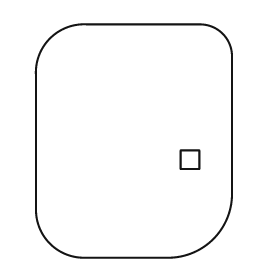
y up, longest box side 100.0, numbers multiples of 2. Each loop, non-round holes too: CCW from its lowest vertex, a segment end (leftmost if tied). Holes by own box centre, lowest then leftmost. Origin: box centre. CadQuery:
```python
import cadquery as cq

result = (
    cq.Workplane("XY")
    .moveTo(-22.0, -50.0)
    .lineTo(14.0, -50.0)
    .threePointArc((34.0, -42.0), (42.0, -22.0))
    .lineTo(42.0, 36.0)
    .threePointArc((38.0, 46.0), (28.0, 50.0))
    .lineTo(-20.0, 50.0)
    .threePointArc((-36.0, 44.0), (-42.0, 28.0))
    .lineTo(-42.0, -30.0)
    .threePointArc((-36.0, -44.0), (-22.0, -50.0))
    .close()
    .moveTo(20.0, -12.0)
    .lineTo(28.0, -12.0)
    .lineTo(28.0, -4.0)
    .lineTo(20.0, -4.0)
    .close()
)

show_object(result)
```